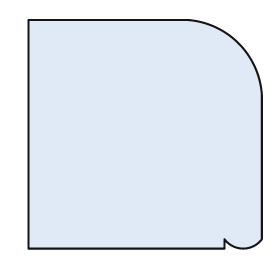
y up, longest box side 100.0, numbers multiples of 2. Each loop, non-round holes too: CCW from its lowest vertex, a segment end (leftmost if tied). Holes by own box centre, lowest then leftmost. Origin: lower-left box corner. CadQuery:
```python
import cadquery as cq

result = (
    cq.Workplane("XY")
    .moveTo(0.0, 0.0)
    .lineTo(84.0, 0.0)
    .lineTo(84.0, 4.0)
    .threePointArc((92.0, 0.0), (100.0, 4.0))
    .lineTo(100.0, 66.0)
    .threePointArc((90.0, 88.0), (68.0, 98.0))
    .lineTo(0.0, 98.0)
    .close()
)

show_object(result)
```